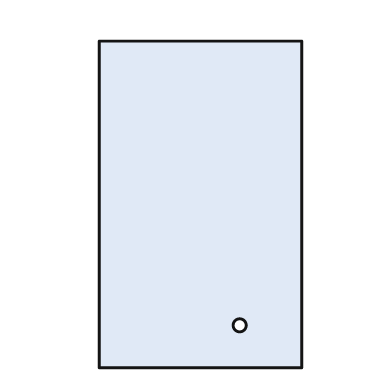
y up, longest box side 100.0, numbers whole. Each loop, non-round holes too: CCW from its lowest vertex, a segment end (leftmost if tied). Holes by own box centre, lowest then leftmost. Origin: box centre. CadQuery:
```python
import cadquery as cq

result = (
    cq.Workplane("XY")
    .moveTo(-31.0, -50.0)
    .lineTo(31.0, -50.0)
    .lineTo(31.0, 50.0)
    .lineTo(-31.0, 50.0)
    .close()
    .moveTo(12.0, -37.0)
    .circle(2.0)
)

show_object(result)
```